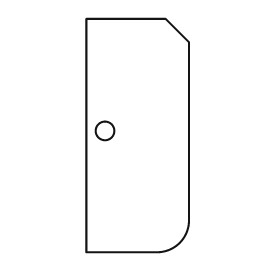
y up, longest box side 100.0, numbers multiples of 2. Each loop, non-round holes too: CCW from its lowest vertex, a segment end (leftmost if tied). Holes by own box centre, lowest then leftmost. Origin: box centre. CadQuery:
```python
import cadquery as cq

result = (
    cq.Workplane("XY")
    .moveTo(-22.0, -50.0)
    .lineTo(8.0, -50.0)
    .threePointArc((18.0, -46.0), (22.0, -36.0))
    .lineTo(22.0, 40.0)
    .lineTo(12.0, 50.0)
    .lineTo(-22.0, 50.0)
    .close()
    .moveTo(-14.0, 2.0)
    .circle(4.0)
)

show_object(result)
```